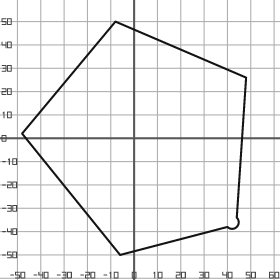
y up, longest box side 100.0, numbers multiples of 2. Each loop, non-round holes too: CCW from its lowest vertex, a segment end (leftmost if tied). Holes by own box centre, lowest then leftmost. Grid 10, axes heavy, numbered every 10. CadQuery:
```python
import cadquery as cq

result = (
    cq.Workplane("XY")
    .moveTo(-6.0, -50.0)
    .lineTo(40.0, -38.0)
    .threePointArc((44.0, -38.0), (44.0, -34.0))
    .lineTo(48.0, 26.0)
    .lineTo(-8.0, 50.0)
    .lineTo(-48.0, 2.0)
    .close()
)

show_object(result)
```